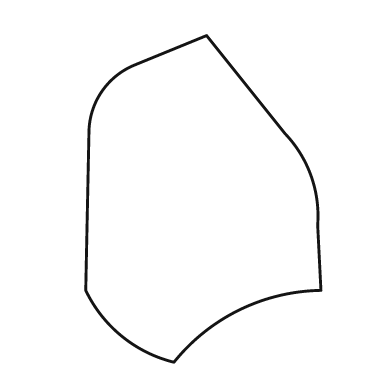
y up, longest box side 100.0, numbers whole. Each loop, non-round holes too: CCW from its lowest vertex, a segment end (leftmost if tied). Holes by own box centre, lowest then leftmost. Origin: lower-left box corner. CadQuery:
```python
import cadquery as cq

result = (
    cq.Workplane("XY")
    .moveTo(27.0, 0.0)
    .threePointArc((47.0, 16.0), (72.0, 22.0))
    .lineTo(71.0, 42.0)
    .threePointArc((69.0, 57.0), (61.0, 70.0))
    .lineTo(37.0, 100.0)
    .lineTo(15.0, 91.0)
    .threePointArc((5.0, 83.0), (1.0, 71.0))
    .lineTo(0.0, 22.0)
    .threePointArc((11.0, 8.0), (27.0, 0.0))
    .close()
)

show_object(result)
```